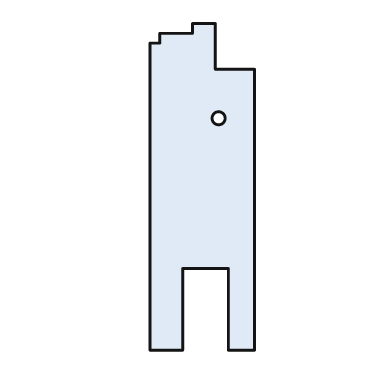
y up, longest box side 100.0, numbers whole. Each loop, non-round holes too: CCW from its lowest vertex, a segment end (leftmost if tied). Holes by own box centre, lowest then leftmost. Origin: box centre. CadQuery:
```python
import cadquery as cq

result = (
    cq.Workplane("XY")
    .moveTo(-16.0, -50.0)
    .lineTo(-6.0, -50.0)
    .lineTo(-6.0, -25.0)
    .lineTo(8.0, -25.0)
    .lineTo(8.0, -50.0)
    .lineTo(16.0, -50.0)
    .lineTo(16.0, 36.0)
    .lineTo(4.0, 36.0)
    .lineTo(4.0, 50.0)
    .lineTo(-3.0, 50.0)
    .lineTo(-3.0, 47.0)
    .lineTo(-13.0, 47.0)
    .lineTo(-13.0, 44.0)
    .lineTo(-16.0, 44.0)
    .close()
    .moveTo(5.0, 21.0)
    .circle(2.0)
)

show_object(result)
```